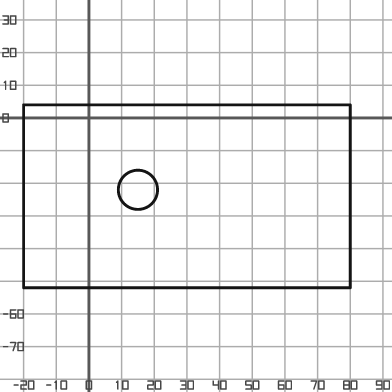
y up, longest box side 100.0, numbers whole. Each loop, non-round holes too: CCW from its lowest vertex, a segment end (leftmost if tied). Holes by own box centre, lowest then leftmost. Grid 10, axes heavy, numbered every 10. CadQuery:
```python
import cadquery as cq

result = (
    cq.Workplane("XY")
    .moveTo(-20.0, -52.0)
    .lineTo(80.0, -52.0)
    .lineTo(80.0, 4.0)
    .lineTo(-20.0, 4.0)
    .close()
    .moveTo(15.0, -22.0)
    .circle(6.0)
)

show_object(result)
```